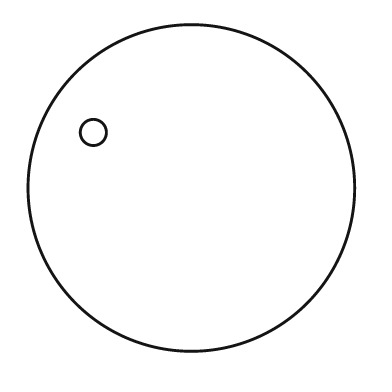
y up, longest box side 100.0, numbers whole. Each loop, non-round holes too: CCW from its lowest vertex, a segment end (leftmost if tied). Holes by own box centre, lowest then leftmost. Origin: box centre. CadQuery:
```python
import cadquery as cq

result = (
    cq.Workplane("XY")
    .moveTo(0.0, 0.0)
    .circle(50.0)
    .moveTo(-30.0, 17.0)
    .circle(4.0)
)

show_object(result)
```